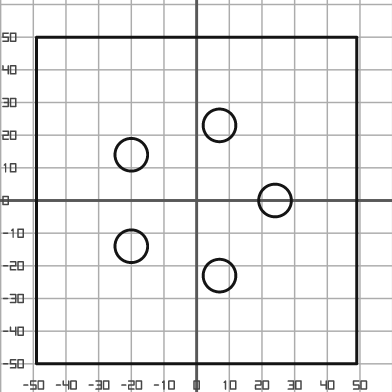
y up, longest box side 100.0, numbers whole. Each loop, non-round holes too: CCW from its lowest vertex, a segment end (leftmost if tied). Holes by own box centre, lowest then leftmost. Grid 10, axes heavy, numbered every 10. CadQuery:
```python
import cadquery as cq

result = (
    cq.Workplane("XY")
    .moveTo(-49.0, -50.0)
    .lineTo(49.0, -50.0)
    .lineTo(49.0, 50.0)
    .lineTo(-49.0, 50.0)
    .close()
    .moveTo(7.0, -23.0)
    .circle(5.0)
    .moveTo(-20.0, -14.0)
    .circle(5.0)
    .moveTo(24.0, 0.0)
    .circle(5.0)
    .moveTo(-20.0, 14.0)
    .circle(5.0)
    .moveTo(7.0, 23.0)
    .circle(5.0)
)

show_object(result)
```